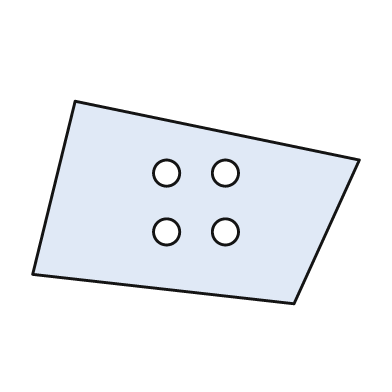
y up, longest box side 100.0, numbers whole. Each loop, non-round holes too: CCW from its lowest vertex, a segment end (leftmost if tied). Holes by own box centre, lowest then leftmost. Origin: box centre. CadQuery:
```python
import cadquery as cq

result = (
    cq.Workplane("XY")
    .moveTo(30.0, -31.0)
    .lineTo(50.0, 13.0)
    .lineTo(-37.0, 31.0)
    .lineTo(-50.0, -22.0)
    .close()
    .moveTo(-9.0, -9.0)
    .circle(4.0)
    .moveTo(9.0, -9.0)
    .circle(4.0)
    .moveTo(-9.0, 9.0)
    .circle(4.0)
    .moveTo(9.0, 9.0)
    .circle(4.0)
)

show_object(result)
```